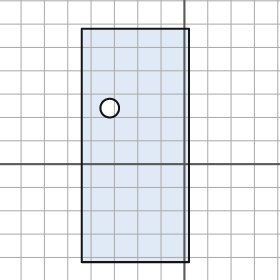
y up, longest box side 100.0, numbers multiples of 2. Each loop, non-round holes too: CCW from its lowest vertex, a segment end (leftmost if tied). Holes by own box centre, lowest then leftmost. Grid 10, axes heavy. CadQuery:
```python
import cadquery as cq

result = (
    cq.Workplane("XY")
    .moveTo(-44.0, -42.0)
    .lineTo(2.0, -42.0)
    .lineTo(2.0, 58.0)
    .lineTo(-44.0, 58.0)
    .close()
    .moveTo(-32.0, 24.0)
    .circle(4.0)
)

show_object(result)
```